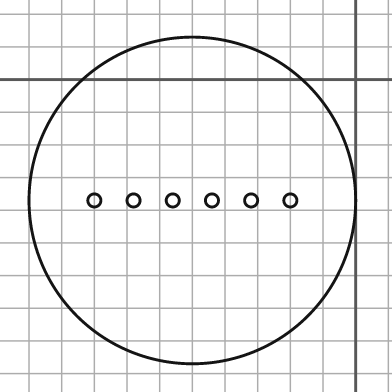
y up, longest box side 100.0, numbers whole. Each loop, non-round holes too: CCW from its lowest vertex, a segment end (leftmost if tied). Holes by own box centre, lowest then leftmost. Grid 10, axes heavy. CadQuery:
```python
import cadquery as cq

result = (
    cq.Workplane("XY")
    .moveTo(-50.0, -37.0)
    .circle(50.0)
    .moveTo(-80.0, -37.0)
    .circle(2.0)
    .moveTo(-68.0, -37.0)
    .circle(2.0)
    .moveTo(-56.0, -37.0)
    .circle(2.0)
    .moveTo(-44.0, -37.0)
    .circle(2.0)
    .moveTo(-32.0, -37.0)
    .circle(2.0)
    .moveTo(-20.0, -37.0)
    .circle(2.0)
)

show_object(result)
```